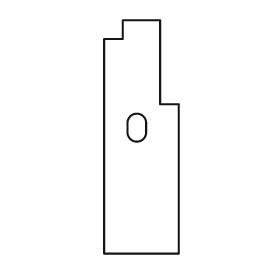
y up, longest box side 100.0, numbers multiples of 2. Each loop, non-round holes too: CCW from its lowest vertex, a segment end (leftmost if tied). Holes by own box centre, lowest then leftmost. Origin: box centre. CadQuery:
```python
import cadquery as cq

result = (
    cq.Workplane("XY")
    .moveTo(-16.0, -50.0)
    .lineTo(16.0, -50.0)
    .lineTo(16.0, 14.0)
    .lineTo(8.0, 14.0)
    .lineTo(8.0, 50.0)
    .lineTo(-8.0, 50.0)
    .lineTo(-8.0, 42.0)
    .lineTo(-16.0, 42.0)
    .close()
    .moveTo(-6.0, 2.0)
    .threePointArc((-2.0, -2.0), (2.0, 2.0))
    .lineTo(2.0, 6.0)
    .threePointArc((-2.0, 10.0), (-6.0, 6.0))
    .close()
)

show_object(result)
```